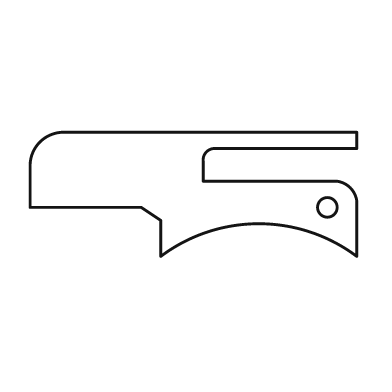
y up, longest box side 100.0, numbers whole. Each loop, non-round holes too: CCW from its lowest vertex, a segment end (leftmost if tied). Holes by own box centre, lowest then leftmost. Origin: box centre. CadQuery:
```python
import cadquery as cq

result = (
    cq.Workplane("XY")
    .moveTo(-10.0, -19.0)
    .threePointArc((20.0, -9.0), (50.0, -19.0))
    .lineTo(50.0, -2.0)
    .threePointArc((48.0, 2.0), (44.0, 4.0))
    .lineTo(3.0, 4.0)
    .lineTo(3.0, 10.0)
    .threePointArc((4.0, 13.0), (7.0, 14.0))
    .lineTo(50.0, 14.0)
    .lineTo(50.0, 19.0)
    .lineTo(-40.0, 19.0)
    .threePointArc((-47.0, 16.0), (-50.0, 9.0))
    .lineTo(-50.0, -4.0)
    .lineTo(-16.0, -4.0)
    .lineTo(-10.0, -8.0)
    .close()
    .moveTo(41.0, -4.0)
    .circle(3.0)
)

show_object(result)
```